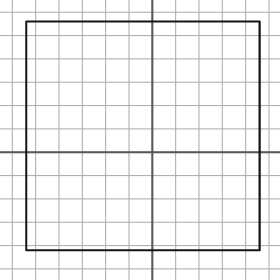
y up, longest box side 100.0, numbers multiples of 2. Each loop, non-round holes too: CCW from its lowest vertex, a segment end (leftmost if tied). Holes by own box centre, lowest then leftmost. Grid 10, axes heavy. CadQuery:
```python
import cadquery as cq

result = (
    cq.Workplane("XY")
    .moveTo(-54.0, -42.0)
    .lineTo(46.0, -42.0)
    .lineTo(46.0, 56.0)
    .lineTo(-54.0, 56.0)
    .close()
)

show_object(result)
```